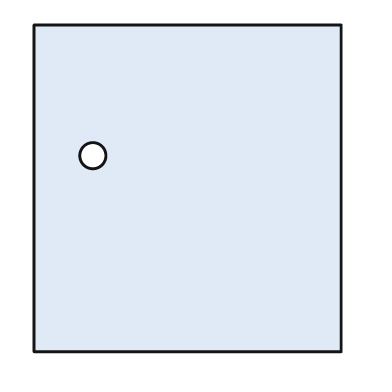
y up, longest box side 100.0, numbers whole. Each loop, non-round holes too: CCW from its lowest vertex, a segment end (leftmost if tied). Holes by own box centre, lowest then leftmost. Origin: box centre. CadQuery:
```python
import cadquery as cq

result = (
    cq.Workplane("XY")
    .moveTo(-47.0, -50.0)
    .lineTo(47.0, -50.0)
    .lineTo(47.0, 50.0)
    .lineTo(-47.0, 50.0)
    .close()
    .moveTo(-29.0, 10.0)
    .circle(4.0)
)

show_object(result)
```